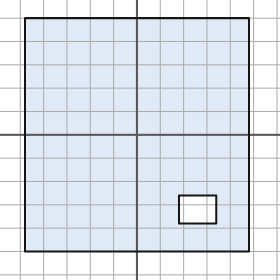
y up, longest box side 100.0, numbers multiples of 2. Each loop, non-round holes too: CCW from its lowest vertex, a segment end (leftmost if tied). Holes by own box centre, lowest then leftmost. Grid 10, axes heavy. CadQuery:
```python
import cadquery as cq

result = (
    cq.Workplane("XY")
    .moveTo(-48.0, -50.0)
    .lineTo(48.0, -50.0)
    .lineTo(48.0, 50.0)
    .lineTo(-48.0, 50.0)
    .close()
    .moveTo(18.0, -38.0)
    .lineTo(34.0, -38.0)
    .lineTo(34.0, -26.0)
    .lineTo(18.0, -26.0)
    .close()
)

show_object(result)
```